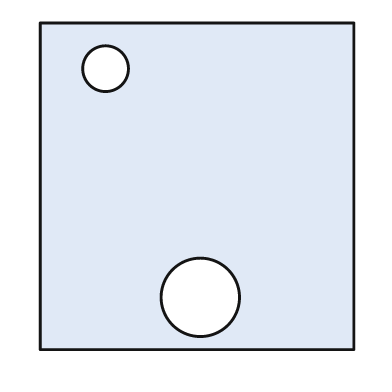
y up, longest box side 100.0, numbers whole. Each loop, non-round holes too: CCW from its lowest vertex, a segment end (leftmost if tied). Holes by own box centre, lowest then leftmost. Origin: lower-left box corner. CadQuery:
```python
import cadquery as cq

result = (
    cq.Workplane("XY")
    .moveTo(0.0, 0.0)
    .lineTo(96.0, 0.0)
    .lineTo(96.0, 100.0)
    .lineTo(0.0, 100.0)
    .close()
    .moveTo(49.0, 16.0)
    .circle(12.0)
    .moveTo(20.0, 86.0)
    .circle(7.0)
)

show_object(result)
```